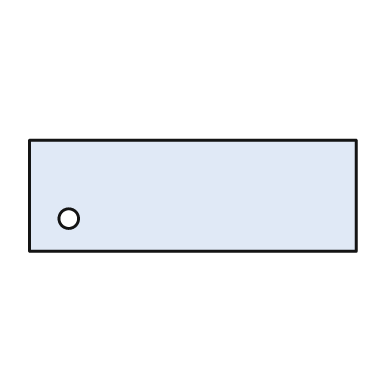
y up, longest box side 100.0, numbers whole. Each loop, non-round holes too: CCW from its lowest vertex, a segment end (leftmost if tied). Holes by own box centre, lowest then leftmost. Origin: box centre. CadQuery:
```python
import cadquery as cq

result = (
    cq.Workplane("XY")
    .moveTo(-50.0, -17.0)
    .lineTo(50.0, -17.0)
    .lineTo(50.0, 17.0)
    .lineTo(-50.0, 17.0)
    .close()
    .moveTo(-38.0, -7.0)
    .circle(3.0)
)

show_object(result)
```